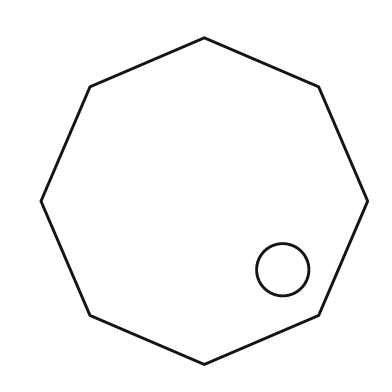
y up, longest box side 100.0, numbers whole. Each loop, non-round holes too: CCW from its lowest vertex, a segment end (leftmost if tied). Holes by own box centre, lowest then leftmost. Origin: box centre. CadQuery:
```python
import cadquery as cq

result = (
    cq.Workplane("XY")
    .moveTo(0.0, -50.0)
    .lineTo(35.0, -35.0)
    .lineTo(50.0, 0.0)
    .lineTo(35.0, 35.0)
    .lineTo(0.0, 50.0)
    .lineTo(-35.0, 35.0)
    .lineTo(-50.0, 0.0)
    .lineTo(-35.0, -35.0)
    .close()
    .moveTo(24.0, -21.0)
    .circle(8.0)
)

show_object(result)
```